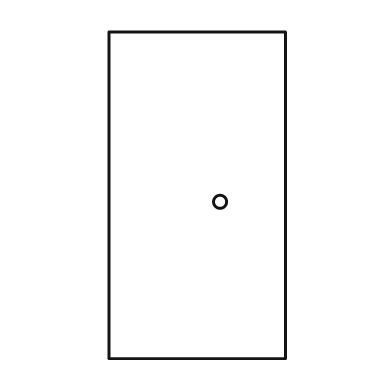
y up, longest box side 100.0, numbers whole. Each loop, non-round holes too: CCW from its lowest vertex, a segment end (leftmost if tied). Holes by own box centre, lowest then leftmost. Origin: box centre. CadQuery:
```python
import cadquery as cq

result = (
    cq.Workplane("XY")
    .moveTo(-27.0, -50.0)
    .lineTo(27.0, -50.0)
    .lineTo(27.0, 50.0)
    .lineTo(-27.0, 50.0)
    .close()
    .moveTo(7.0, -2.0)
    .circle(2.0)
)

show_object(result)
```